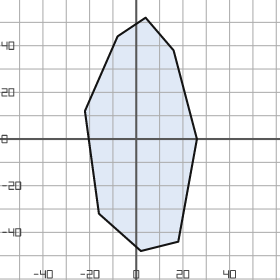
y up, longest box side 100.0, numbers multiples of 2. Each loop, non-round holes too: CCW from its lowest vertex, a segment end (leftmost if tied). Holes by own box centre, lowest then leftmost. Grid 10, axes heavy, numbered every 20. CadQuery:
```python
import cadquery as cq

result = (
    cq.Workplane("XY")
    .moveTo(2.0, -48.0)
    .lineTo(18.0, -44.0)
    .lineTo(26.0, 0.0)
    .lineTo(16.0, 38.0)
    .lineTo(4.0, 52.0)
    .lineTo(-8.0, 44.0)
    .lineTo(-22.0, 12.0)
    .lineTo(-16.0, -32.0)
    .close()
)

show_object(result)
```